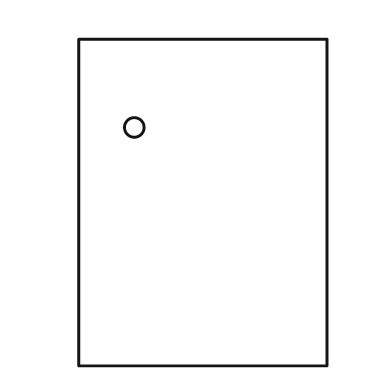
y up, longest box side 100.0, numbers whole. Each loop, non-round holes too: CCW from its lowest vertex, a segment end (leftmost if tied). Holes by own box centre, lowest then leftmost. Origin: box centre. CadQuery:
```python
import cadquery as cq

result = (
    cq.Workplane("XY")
    .moveTo(-38.0, -50.0)
    .lineTo(38.0, -50.0)
    .lineTo(38.0, 50.0)
    .lineTo(-38.0, 50.0)
    .close()
    .moveTo(-21.0, 23.0)
    .circle(3.0)
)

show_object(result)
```